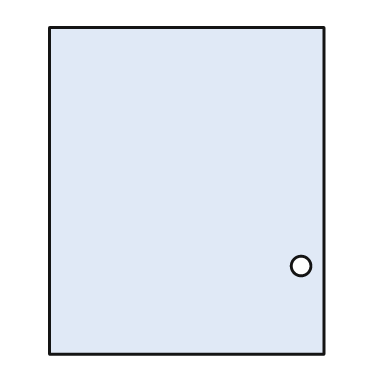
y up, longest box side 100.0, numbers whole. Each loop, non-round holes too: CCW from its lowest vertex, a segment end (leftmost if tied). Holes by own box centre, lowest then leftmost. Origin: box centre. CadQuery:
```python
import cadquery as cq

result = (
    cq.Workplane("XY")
    .moveTo(-42.0, -50.0)
    .lineTo(42.0, -50.0)
    .lineTo(42.0, 50.0)
    .lineTo(-42.0, 50.0)
    .close()
    .moveTo(35.0, -23.0)
    .circle(3.0)
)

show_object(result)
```